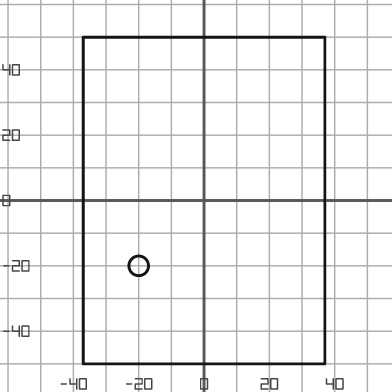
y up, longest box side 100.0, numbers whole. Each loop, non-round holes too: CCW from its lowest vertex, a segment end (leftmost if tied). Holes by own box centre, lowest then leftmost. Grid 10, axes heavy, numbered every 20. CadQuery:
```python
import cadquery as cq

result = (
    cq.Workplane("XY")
    .moveTo(-37.0, -50.0)
    .lineTo(37.0, -50.0)
    .lineTo(37.0, 50.0)
    .lineTo(-37.0, 50.0)
    .close()
    .moveTo(-20.0, -20.0)
    .circle(3.0)
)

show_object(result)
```